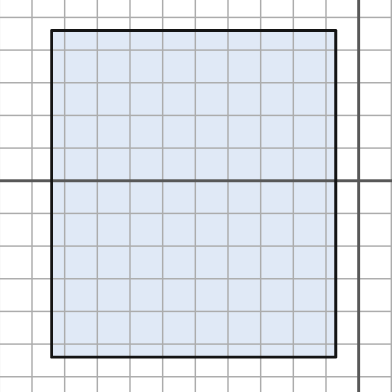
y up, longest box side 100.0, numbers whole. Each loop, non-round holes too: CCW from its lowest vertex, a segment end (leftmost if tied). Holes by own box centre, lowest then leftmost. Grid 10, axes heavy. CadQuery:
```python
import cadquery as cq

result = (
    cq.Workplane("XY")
    .moveTo(-94.0, -54.0)
    .lineTo(-7.0, -54.0)
    .lineTo(-7.0, 46.0)
    .lineTo(-94.0, 46.0)
    .close()
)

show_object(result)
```